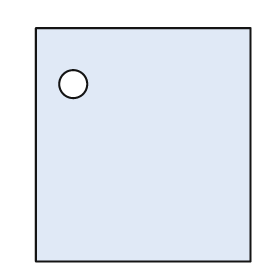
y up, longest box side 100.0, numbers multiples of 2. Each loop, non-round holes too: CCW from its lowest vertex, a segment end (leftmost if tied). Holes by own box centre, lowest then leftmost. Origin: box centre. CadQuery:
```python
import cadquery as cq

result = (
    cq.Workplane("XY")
    .moveTo(-46.0, -50.0)
    .lineTo(46.0, -50.0)
    .lineTo(46.0, 50.0)
    .lineTo(-46.0, 50.0)
    .close()
    .moveTo(-30.0, 26.0)
    .circle(6.0)
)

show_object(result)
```